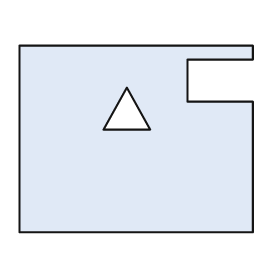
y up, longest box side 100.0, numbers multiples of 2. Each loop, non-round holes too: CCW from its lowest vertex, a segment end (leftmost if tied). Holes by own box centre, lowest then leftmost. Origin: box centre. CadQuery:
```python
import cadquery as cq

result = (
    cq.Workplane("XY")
    .moveTo(-50.0, -40.0)
    .lineTo(50.0, -40.0)
    .lineTo(50.0, 16.0)
    .lineTo(22.0, 16.0)
    .lineTo(22.0, 34.0)
    .lineTo(50.0, 34.0)
    .lineTo(50.0, 40.0)
    .lineTo(-50.0, 40.0)
    .close()
    .moveTo(-14.0, 4.0)
    .lineTo(6.0, 4.0)
    .lineTo(-4.0, 22.0)
    .close()
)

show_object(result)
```